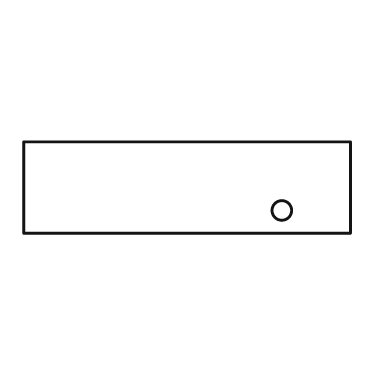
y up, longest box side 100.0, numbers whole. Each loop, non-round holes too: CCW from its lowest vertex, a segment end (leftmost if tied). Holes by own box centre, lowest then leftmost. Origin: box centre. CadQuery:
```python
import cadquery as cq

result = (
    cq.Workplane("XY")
    .moveTo(-50.0, -14.0)
    .lineTo(50.0, -14.0)
    .lineTo(50.0, 14.0)
    .lineTo(-50.0, 14.0)
    .close()
    .moveTo(29.0, -7.0)
    .circle(3.0)
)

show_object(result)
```